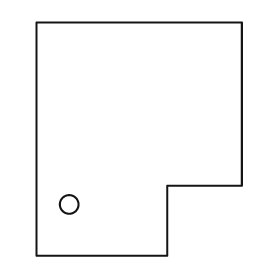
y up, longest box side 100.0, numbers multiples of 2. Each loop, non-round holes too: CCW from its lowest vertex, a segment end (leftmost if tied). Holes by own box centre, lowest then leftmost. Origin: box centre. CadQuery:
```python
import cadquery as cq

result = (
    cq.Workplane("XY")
    .moveTo(-44.0, -50.0)
    .lineTo(12.0, -50.0)
    .lineTo(12.0, -20.0)
    .lineTo(44.0, -20.0)
    .lineTo(44.0, 50.0)
    .lineTo(-44.0, 50.0)
    .close()
    .moveTo(-30.0, -28.0)
    .circle(4.0)
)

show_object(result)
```